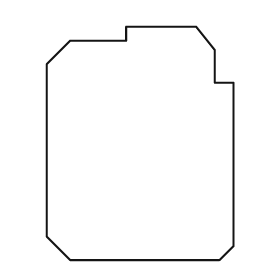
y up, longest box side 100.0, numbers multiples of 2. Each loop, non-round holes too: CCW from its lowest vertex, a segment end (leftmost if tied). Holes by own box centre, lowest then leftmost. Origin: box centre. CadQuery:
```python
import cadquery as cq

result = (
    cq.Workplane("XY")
    .moveTo(-30.0, -50.0)
    .lineTo(34.0, -50.0)
    .lineTo(40.0, -44.0)
    .lineTo(40.0, 26.0)
    .lineTo(32.0, 26.0)
    .lineTo(32.0, 40.0)
    .lineTo(24.0, 50.0)
    .lineTo(-6.0, 50.0)
    .lineTo(-6.0, 44.0)
    .lineTo(-30.0, 44.0)
    .lineTo(-40.0, 34.0)
    .lineTo(-40.0, -40.0)
    .close()
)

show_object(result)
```